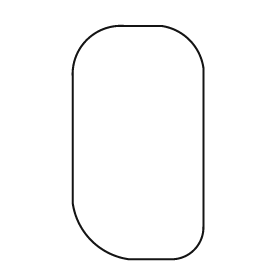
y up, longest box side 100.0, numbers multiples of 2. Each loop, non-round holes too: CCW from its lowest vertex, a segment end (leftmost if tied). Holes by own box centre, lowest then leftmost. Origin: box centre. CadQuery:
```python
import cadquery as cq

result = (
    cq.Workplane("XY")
    .moveTo(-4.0, -50.0)
    .lineTo(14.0, -50.0)
    .threePointArc((24.0, -46.0), (28.0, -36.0))
    .lineTo(28.0, 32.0)
    .threePointArc((22.0, 44.0), (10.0, 50.0))
    .lineTo(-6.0, 50.0)
    .threePointArc((-22.0, 44.0), (-28.0, 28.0))
    .lineTo(-28.0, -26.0)
    .threePointArc((-20.0, -42.0), (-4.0, -50.0))
    .close()
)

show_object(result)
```